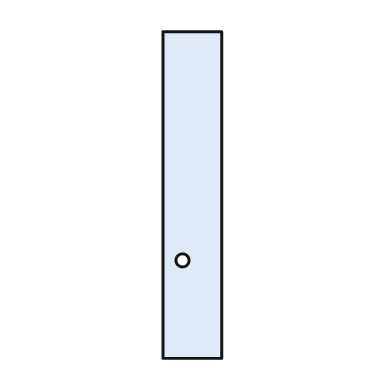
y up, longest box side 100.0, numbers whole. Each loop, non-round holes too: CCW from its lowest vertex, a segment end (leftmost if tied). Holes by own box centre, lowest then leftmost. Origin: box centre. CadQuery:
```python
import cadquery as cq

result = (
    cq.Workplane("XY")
    .moveTo(-9.0, -50.0)
    .lineTo(9.0, -50.0)
    .lineTo(9.0, 50.0)
    .lineTo(-9.0, 50.0)
    .close()
    .moveTo(-3.0, -20.0)
    .circle(2.0)
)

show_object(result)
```